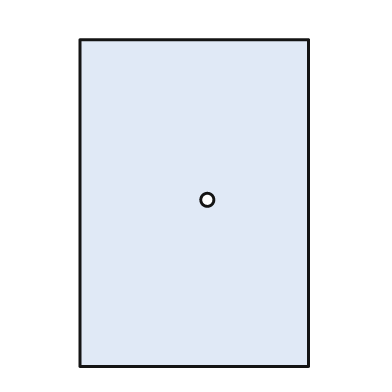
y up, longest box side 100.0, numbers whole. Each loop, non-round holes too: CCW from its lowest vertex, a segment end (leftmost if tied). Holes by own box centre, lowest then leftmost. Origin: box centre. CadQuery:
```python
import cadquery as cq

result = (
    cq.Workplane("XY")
    .moveTo(-35.0, -50.0)
    .lineTo(35.0, -50.0)
    .lineTo(35.0, 50.0)
    .lineTo(-35.0, 50.0)
    .close()
    .moveTo(4.0, 1.0)
    .circle(2.0)
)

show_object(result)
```